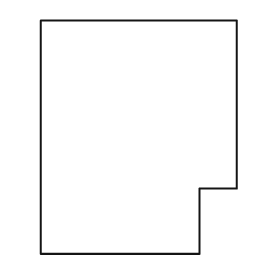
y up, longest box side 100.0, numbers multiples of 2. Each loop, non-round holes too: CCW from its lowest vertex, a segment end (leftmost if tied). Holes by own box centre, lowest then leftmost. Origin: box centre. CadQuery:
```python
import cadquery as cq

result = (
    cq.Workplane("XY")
    .moveTo(-42.0, -50.0)
    .lineTo(26.0, -50.0)
    .lineTo(26.0, -22.0)
    .lineTo(42.0, -22.0)
    .lineTo(42.0, 50.0)
    .lineTo(-42.0, 50.0)
    .close()
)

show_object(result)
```